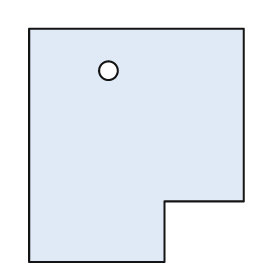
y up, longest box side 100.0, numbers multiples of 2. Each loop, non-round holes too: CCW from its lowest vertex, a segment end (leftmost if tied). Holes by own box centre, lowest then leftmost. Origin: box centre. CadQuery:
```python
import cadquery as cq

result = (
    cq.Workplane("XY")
    .moveTo(-46.0, -50.0)
    .lineTo(12.0, -50.0)
    .lineTo(12.0, -24.0)
    .lineTo(46.0, -24.0)
    .lineTo(46.0, 50.0)
    .lineTo(-46.0, 50.0)
    .close()
    .moveTo(-12.0, 32.0)
    .circle(4.0)
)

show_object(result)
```